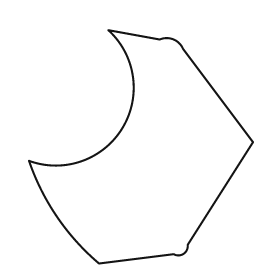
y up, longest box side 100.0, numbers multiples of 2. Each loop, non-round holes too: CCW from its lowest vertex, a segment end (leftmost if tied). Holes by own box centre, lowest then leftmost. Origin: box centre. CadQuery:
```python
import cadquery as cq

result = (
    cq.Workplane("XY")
    .moveTo(-18.0, -50.0)
    .lineTo(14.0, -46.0)
    .threePointArc((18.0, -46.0), (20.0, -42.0))
    .lineTo(48.0, 2.0)
    .lineTo(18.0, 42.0)
    .threePointArc((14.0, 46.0), (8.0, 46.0))
    .lineTo(-14.0, 50.0)
    .threePointArc((-8.0, 8.0), (-48.0, -6.0))
    .threePointArc((-36.0, -30.0), (-18.0, -50.0))
    .close()
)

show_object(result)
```